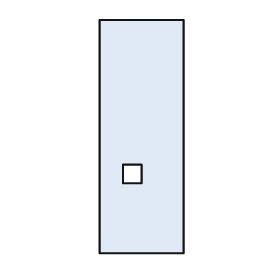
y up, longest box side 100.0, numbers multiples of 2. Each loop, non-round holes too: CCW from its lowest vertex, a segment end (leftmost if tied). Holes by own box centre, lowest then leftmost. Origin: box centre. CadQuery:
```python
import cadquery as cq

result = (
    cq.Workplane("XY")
    .moveTo(-18.0, -50.0)
    .lineTo(18.0, -50.0)
    .lineTo(18.0, 50.0)
    .lineTo(-18.0, 50.0)
    .close()
    .moveTo(-8.0, -20.0)
    .lineTo(0.0, -20.0)
    .lineTo(0.0, -12.0)
    .lineTo(-8.0, -12.0)
    .close()
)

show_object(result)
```